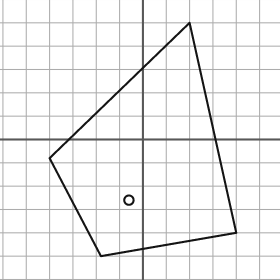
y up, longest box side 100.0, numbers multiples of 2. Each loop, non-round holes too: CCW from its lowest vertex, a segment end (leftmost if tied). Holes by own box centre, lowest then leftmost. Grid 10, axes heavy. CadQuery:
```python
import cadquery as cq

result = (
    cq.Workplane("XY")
    .moveTo(-18.0, -50.0)
    .lineTo(40.0, -40.0)
    .lineTo(20.0, 50.0)
    .lineTo(-40.0, -8.0)
    .close()
    .moveTo(-6.0, -26.0)
    .circle(2.0)
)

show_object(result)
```